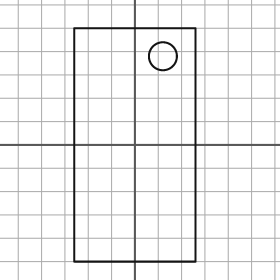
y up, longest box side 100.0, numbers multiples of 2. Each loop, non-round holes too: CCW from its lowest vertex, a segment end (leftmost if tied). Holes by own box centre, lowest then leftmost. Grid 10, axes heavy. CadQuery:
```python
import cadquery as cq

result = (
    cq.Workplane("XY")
    .moveTo(-26.0, -50.0)
    .lineTo(26.0, -50.0)
    .lineTo(26.0, 50.0)
    .lineTo(-26.0, 50.0)
    .close()
    .moveTo(12.0, 38.0)
    .circle(6.0)
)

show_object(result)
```